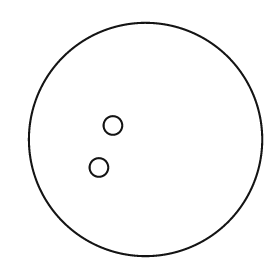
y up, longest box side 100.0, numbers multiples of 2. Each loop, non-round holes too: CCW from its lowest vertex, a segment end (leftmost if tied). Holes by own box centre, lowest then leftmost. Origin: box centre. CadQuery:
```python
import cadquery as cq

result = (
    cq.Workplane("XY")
    .moveTo(0.0, 0.0)
    .circle(50.0)
    .moveTo(-20.0, -12.0)
    .circle(4.0)
    .moveTo(-14.0, 6.0)
    .circle(4.0)
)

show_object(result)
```